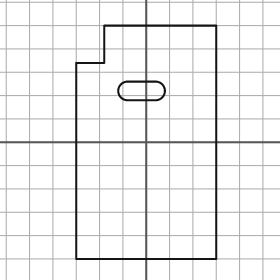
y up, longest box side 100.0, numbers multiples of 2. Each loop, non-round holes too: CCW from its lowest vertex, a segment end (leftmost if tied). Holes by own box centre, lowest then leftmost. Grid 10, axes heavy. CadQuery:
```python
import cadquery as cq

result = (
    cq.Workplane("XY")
    .moveTo(-30.0, -50.0)
    .lineTo(30.0, -50.0)
    .lineTo(30.0, 50.0)
    .lineTo(-18.0, 50.0)
    .lineTo(-18.0, 34.0)
    .lineTo(-30.0, 34.0)
    .close()
    .moveTo(-8.0, 18.0)
    .lineTo(4.0, 18.0)
    .threePointArc((8.0, 22.0), (4.0, 26.0))
    .lineTo(-8.0, 26.0)
    .threePointArc((-12.0, 22.0), (-8.0, 18.0))
    .close()
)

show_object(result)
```